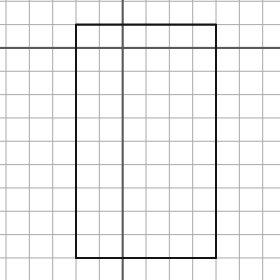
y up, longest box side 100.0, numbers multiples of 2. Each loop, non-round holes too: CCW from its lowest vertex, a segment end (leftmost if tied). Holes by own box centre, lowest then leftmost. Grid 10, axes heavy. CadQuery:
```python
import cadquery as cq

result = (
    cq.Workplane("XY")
    .moveTo(-20.0, -90.0)
    .lineTo(40.0, -90.0)
    .lineTo(40.0, 10.0)
    .lineTo(-20.0, 10.0)
    .close()
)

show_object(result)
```